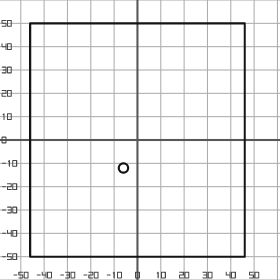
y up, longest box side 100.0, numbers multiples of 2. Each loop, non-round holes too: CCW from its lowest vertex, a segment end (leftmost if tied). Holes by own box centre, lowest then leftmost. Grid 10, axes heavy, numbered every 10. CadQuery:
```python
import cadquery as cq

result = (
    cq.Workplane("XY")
    .moveTo(-46.0, -50.0)
    .lineTo(46.0, -50.0)
    .lineTo(46.0, 50.0)
    .lineTo(-46.0, 50.0)
    .close()
    .moveTo(-6.0, -12.0)
    .circle(2.0)
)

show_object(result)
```